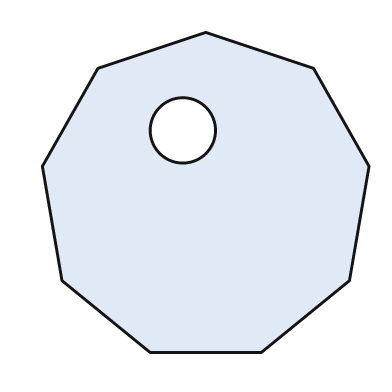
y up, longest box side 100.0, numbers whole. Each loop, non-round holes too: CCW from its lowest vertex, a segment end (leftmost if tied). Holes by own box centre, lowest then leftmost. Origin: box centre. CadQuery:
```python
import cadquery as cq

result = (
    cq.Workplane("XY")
    .moveTo(-17.0, -49.0)
    .lineTo(17.0, -49.0)
    .lineTo(44.0, -27.0)
    .lineTo(50.0, 8.0)
    .lineTo(33.0, 38.0)
    .lineTo(0.0, 49.0)
    .lineTo(-33.0, 38.0)
    .lineTo(-50.0, 8.0)
    .lineTo(-44.0, -27.0)
    .close()
    .moveTo(-7.0, 19.0)
    .circle(10.0)
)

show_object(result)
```